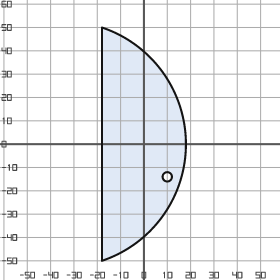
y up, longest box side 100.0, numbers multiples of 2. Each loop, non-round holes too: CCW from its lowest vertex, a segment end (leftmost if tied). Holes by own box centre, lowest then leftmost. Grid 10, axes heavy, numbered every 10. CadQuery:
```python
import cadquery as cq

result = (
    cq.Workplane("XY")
    .moveTo(-18.0, -50.0)
    .threePointArc((18.0, 0.0), (-18.0, 50.0))
    .close()
    .moveTo(10.0, -14.0)
    .circle(2.0)
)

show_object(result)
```